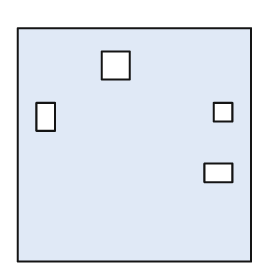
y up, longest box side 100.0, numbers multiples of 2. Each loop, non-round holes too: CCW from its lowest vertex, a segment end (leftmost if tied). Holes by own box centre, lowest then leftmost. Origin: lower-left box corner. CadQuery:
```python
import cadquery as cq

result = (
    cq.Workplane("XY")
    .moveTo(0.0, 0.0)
    .lineTo(100.0, 0.0)
    .lineTo(100.0, 100.0)
    .lineTo(0.0, 100.0)
    .close()
    .moveTo(80.0, 34.0)
    .lineTo(92.0, 34.0)
    .lineTo(92.0, 42.0)
    .lineTo(80.0, 42.0)
    .close()
    .moveTo(8.0, 56.0)
    .lineTo(16.0, 56.0)
    .lineTo(16.0, 68.0)
    .lineTo(8.0, 68.0)
    .close()
    .moveTo(84.0, 60.0)
    .lineTo(92.0, 60.0)
    .lineTo(92.0, 68.0)
    .lineTo(84.0, 68.0)
    .close()
    .moveTo(36.0, 78.0)
    .lineTo(48.0, 78.0)
    .lineTo(48.0, 90.0)
    .lineTo(36.0, 90.0)
    .close()
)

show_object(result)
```